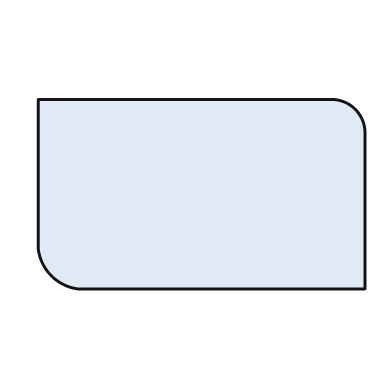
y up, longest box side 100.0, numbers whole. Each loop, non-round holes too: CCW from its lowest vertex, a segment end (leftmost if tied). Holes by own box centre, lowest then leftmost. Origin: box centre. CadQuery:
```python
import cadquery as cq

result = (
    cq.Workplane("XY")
    .moveTo(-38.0, -29.0)
    .lineTo(50.0, -29.0)
    .lineTo(50.0, 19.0)
    .threePointArc((47.0, 26.0), (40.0, 29.0))
    .lineTo(-50.0, 29.0)
    .lineTo(-50.0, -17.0)
    .threePointArc((-46.0, -25.0), (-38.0, -29.0))
    .close()
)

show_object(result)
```